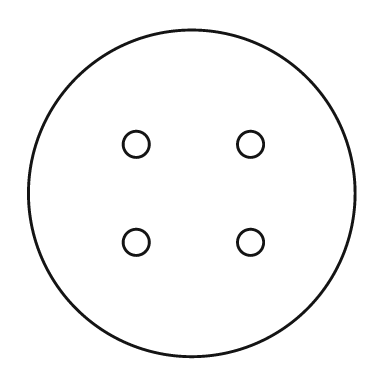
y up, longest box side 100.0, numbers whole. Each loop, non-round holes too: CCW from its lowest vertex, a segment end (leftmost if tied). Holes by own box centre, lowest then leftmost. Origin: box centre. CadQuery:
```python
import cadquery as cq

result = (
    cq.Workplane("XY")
    .moveTo(0.0, 0.0)
    .circle(50.0)
    .moveTo(-17.0, -15.0)
    .circle(4.0)
    .moveTo(18.0, -15.0)
    .circle(4.0)
    .moveTo(-17.0, 15.0)
    .circle(4.0)
    .moveTo(18.0, 15.0)
    .circle(4.0)
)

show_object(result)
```